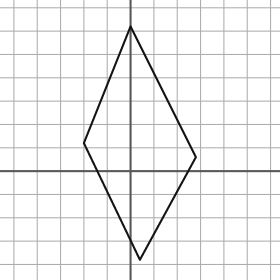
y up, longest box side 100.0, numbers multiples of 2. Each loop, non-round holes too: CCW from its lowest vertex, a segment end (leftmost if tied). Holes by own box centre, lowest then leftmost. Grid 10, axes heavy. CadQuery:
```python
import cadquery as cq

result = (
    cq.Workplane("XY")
    .moveTo(4.0, -38.0)
    .lineTo(28.0, 6.0)
    .lineTo(0.0, 62.0)
    .lineTo(-20.0, 12.0)
    .close()
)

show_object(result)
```